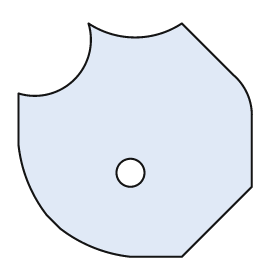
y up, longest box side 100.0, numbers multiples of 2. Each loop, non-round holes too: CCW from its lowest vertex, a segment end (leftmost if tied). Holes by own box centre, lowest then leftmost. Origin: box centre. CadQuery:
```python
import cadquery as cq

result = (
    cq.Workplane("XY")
    .moveTo(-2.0, -50.0)
    .lineTo(20.0, -50.0)
    .lineTo(50.0, -20.0)
    .lineTo(50.0, 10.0)
    .threePointArc((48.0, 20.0), (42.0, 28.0))
    .lineTo(20.0, 50.0)
    .threePointArc((0.0, 44.0), (-20.0, 50.0))
    .threePointArc((-26.0, 26.0), (-50.0, 20.0))
    .lineTo(-50.0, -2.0)
    .threePointArc((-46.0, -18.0), (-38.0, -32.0))
    .lineTo(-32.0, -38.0)
    .threePointArc((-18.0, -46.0), (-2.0, -50.0))
    .close()
    .moveTo(-2.0, -14.0)
    .circle(6.0)
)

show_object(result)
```